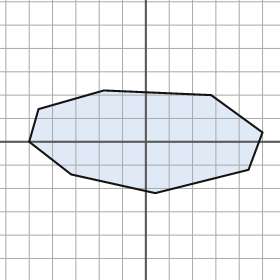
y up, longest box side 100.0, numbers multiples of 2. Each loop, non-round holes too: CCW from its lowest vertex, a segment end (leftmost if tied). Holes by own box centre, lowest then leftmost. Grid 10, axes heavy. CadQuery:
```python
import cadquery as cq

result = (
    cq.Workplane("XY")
    .moveTo(4.0, -22.0)
    .lineTo(44.0, -12.0)
    .lineTo(50.0, 4.0)
    .lineTo(28.0, 20.0)
    .lineTo(-18.0, 22.0)
    .lineTo(-46.0, 14.0)
    .lineTo(-50.0, 0.0)
    .lineTo(-32.0, -14.0)
    .close()
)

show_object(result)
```